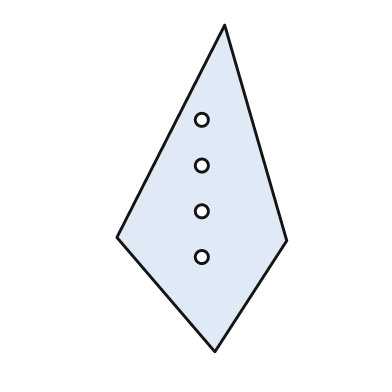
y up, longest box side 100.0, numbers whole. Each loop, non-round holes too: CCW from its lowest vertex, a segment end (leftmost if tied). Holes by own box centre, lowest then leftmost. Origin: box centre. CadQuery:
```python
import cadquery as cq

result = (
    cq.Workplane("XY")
    .moveTo(4.0, -50.0)
    .lineTo(26.0, -16.0)
    .lineTo(7.0, 50.0)
    .lineTo(-26.0, -15.0)
    .close()
    .moveTo(0.0, -21.0)
    .circle(2.0)
    .moveTo(0.0, -7.0)
    .circle(2.0)
    .moveTo(0.0, 7.0)
    .circle(2.0)
    .moveTo(0.0, 21.0)
    .circle(2.0)
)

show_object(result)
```